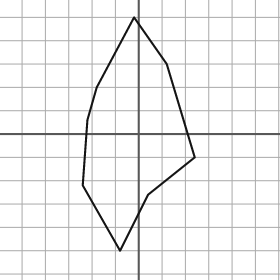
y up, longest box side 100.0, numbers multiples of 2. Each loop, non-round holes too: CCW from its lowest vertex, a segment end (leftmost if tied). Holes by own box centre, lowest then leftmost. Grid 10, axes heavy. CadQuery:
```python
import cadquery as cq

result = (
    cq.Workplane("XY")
    .moveTo(-8.0, -50.0)
    .lineTo(4.0, -26.0)
    .lineTo(24.0, -10.0)
    .lineTo(12.0, 30.0)
    .lineTo(-2.0, 50.0)
    .lineTo(-18.0, 20.0)
    .lineTo(-22.0, 6.0)
    .lineTo(-24.0, -22.0)
    .close()
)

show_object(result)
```